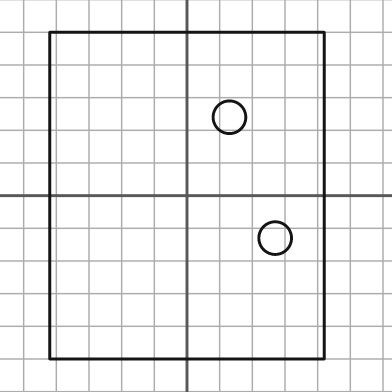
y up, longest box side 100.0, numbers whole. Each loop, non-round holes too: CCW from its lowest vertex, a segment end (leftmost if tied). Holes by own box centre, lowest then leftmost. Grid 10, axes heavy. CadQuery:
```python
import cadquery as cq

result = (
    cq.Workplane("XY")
    .moveTo(-42.0, -50.0)
    .lineTo(42.0, -50.0)
    .lineTo(42.0, 50.0)
    .lineTo(-42.0, 50.0)
    .close()
    .moveTo(27.0, -13.0)
    .circle(5.0)
    .moveTo(13.0, 24.0)
    .circle(5.0)
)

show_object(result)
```